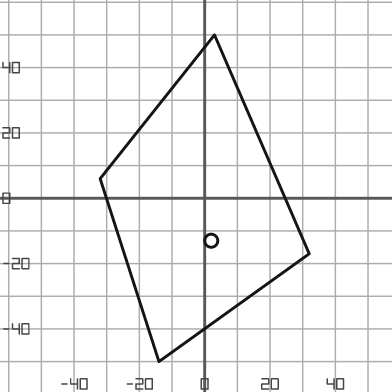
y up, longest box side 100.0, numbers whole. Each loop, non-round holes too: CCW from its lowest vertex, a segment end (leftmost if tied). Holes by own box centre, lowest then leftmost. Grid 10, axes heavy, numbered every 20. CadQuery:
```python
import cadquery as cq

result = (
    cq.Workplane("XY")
    .moveTo(-14.0, -50.0)
    .lineTo(32.0, -17.0)
    .lineTo(3.0, 50.0)
    .lineTo(-32.0, 6.0)
    .close()
    .moveTo(2.0, -13.0)
    .circle(2.0)
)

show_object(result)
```